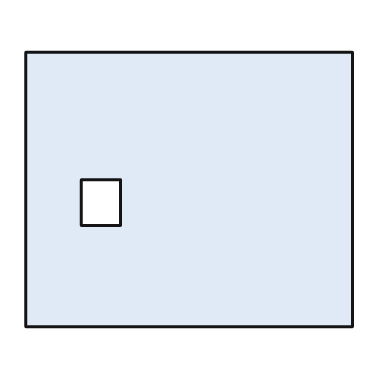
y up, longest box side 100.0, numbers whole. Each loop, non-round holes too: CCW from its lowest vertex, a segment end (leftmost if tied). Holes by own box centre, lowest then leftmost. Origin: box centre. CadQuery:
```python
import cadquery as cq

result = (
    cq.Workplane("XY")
    .moveTo(-50.0, -42.0)
    .lineTo(50.0, -42.0)
    .lineTo(50.0, 42.0)
    .lineTo(-50.0, 42.0)
    .close()
    .moveTo(-33.0, -11.0)
    .lineTo(-21.0, -11.0)
    .lineTo(-21.0, 3.0)
    .lineTo(-33.0, 3.0)
    .close()
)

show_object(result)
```